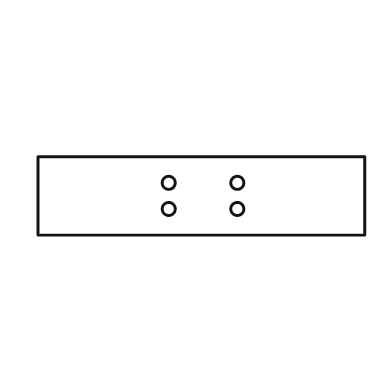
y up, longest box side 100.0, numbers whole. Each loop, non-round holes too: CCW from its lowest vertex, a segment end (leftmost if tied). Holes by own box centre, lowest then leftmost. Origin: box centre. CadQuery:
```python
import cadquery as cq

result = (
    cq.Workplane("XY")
    .moveTo(-50.0, -12.0)
    .lineTo(50.0, -12.0)
    .lineTo(50.0, 12.0)
    .lineTo(-50.0, 12.0)
    .close()
    .moveTo(-10.0, -4.0)
    .circle(2.0)
    .moveTo(11.0, -4.0)
    .circle(2.0)
    .moveTo(-10.0, 4.0)
    .circle(2.0)
    .moveTo(11.0, 4.0)
    .circle(2.0)
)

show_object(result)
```